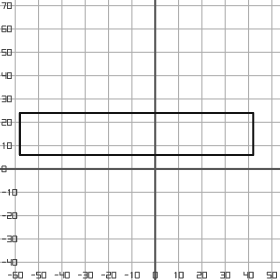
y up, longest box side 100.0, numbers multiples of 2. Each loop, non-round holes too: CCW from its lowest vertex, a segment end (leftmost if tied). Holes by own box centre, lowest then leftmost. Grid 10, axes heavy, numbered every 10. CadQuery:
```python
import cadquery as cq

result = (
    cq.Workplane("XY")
    .moveTo(-58.0, 6.0)
    .lineTo(42.0, 6.0)
    .lineTo(42.0, 24.0)
    .lineTo(-58.0, 24.0)
    .close()
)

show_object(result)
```